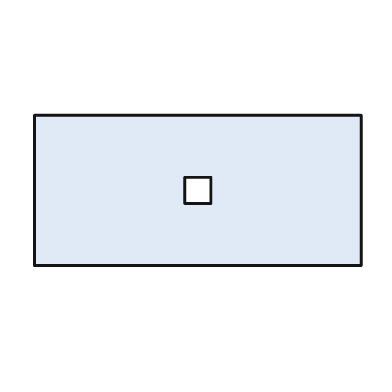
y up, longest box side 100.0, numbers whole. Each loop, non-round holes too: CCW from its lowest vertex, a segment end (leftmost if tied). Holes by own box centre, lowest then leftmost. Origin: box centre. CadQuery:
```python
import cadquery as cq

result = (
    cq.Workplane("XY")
    .moveTo(-50.0, -23.0)
    .lineTo(50.0, -23.0)
    .lineTo(50.0, 23.0)
    .lineTo(-50.0, 23.0)
    .close()
    .moveTo(-4.0, -4.0)
    .lineTo(4.0, -4.0)
    .lineTo(4.0, 4.0)
    .lineTo(-4.0, 4.0)
    .close()
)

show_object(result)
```